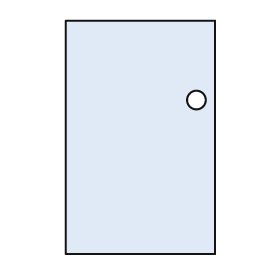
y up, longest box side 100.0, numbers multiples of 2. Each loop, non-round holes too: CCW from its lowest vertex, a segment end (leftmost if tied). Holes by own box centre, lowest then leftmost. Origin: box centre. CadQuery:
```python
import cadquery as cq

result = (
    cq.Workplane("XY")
    .moveTo(-32.0, -50.0)
    .lineTo(32.0, -50.0)
    .lineTo(32.0, 50.0)
    .lineTo(-32.0, 50.0)
    .close()
    .moveTo(24.0, 16.0)
    .circle(4.0)
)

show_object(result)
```